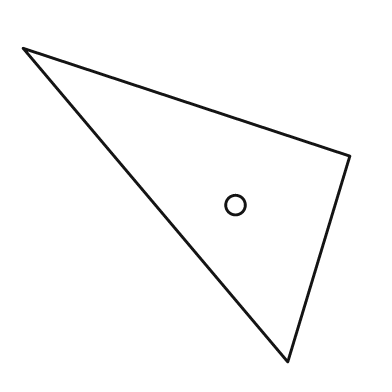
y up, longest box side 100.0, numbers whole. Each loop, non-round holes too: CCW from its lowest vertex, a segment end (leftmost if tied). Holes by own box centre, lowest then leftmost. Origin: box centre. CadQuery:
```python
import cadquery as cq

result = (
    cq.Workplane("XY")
    .moveTo(31.0, -48.0)
    .lineTo(50.0, 15.0)
    .lineTo(-50.0, 48.0)
    .close()
    .moveTo(15.0, 0.0)
    .circle(3.0)
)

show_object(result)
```